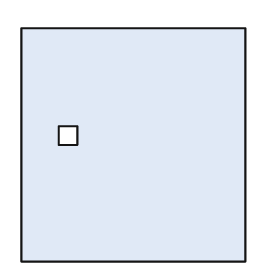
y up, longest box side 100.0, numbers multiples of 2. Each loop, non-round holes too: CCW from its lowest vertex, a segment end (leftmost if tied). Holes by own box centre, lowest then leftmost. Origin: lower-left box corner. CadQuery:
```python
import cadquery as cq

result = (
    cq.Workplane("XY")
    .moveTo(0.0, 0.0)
    .lineTo(96.0, 0.0)
    .lineTo(96.0, 100.0)
    .lineTo(0.0, 100.0)
    .close()
    .moveTo(16.0, 50.0)
    .lineTo(24.0, 50.0)
    .lineTo(24.0, 58.0)
    .lineTo(16.0, 58.0)
    .close()
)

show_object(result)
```